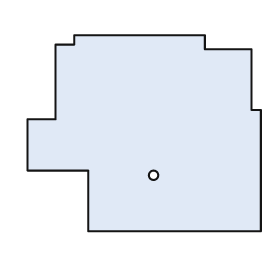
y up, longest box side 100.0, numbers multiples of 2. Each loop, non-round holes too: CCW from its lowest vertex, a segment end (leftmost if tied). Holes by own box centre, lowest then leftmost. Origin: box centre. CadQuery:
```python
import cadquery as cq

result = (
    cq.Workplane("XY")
    .moveTo(-24.0, -42.0)
    .lineTo(50.0, -42.0)
    .lineTo(50.0, 10.0)
    .lineTo(46.0, 10.0)
    .lineTo(46.0, 36.0)
    .lineTo(26.0, 36.0)
    .lineTo(26.0, 42.0)
    .lineTo(-30.0, 42.0)
    .lineTo(-30.0, 38.0)
    .lineTo(-38.0, 38.0)
    .lineTo(-38.0, 6.0)
    .lineTo(-50.0, 6.0)
    .lineTo(-50.0, -16.0)
    .lineTo(-24.0, -16.0)
    .close()
    .moveTo(4.0, -18.0)
    .circle(2.0)
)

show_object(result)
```